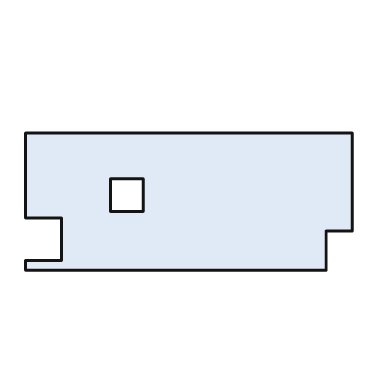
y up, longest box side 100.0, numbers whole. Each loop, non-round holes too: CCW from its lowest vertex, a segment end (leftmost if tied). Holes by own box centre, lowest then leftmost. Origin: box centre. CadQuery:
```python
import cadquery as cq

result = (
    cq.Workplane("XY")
    .moveTo(-50.0, -21.0)
    .lineTo(42.0, -21.0)
    .lineTo(42.0, -9.0)
    .lineTo(50.0, -9.0)
    .lineTo(50.0, 21.0)
    .lineTo(-50.0, 21.0)
    .lineTo(-50.0, -5.0)
    .lineTo(-39.0, -5.0)
    .lineTo(-39.0, -18.0)
    .lineTo(-50.0, -18.0)
    .close()
    .moveTo(-24.0, -3.0)
    .lineTo(-14.0, -3.0)
    .lineTo(-14.0, 7.0)
    .lineTo(-24.0, 7.0)
    .close()
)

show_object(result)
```